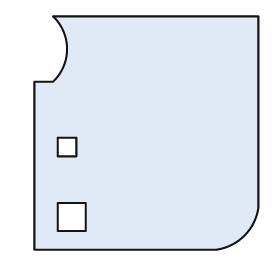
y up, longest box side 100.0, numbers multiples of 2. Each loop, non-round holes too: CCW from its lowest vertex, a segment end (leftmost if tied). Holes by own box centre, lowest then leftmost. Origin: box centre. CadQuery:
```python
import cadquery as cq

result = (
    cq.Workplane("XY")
    .moveTo(-48.0, -50.0)
    .lineTo(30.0, -50.0)
    .threePointArc((42.0, -44.0), (48.0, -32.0))
    .lineTo(48.0, 50.0)
    .lineTo(-40.0, 50.0)
    .threePointArc((-34.0, 36.0), (-40.0, 22.0))
    .lineTo(-48.0, 22.0)
    .close()
    .moveTo(-38.0, -42.0)
    .lineTo(-26.0, -42.0)
    .lineTo(-26.0, -30.0)
    .lineTo(-38.0, -30.0)
    .close()
    .moveTo(-38.0, -10.0)
    .lineTo(-30.0, -10.0)
    .lineTo(-30.0, -2.0)
    .lineTo(-38.0, -2.0)
    .close()
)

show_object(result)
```